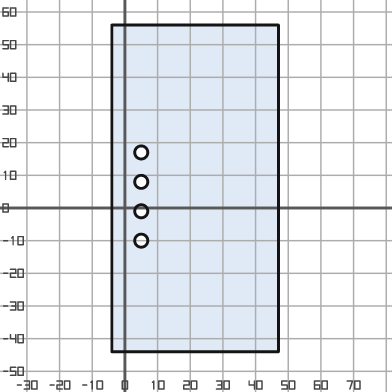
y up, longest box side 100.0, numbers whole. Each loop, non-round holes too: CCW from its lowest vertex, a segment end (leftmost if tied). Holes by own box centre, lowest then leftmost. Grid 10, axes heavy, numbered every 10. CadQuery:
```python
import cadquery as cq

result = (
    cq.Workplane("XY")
    .moveTo(-4.0, -44.0)
    .lineTo(47.0, -44.0)
    .lineTo(47.0, 56.0)
    .lineTo(-4.0, 56.0)
    .close()
    .moveTo(5.0, -10.0)
    .circle(2.0)
    .moveTo(5.0, -1.0)
    .circle(2.0)
    .moveTo(5.0, 8.0)
    .circle(2.0)
    .moveTo(5.0, 17.0)
    .circle(2.0)
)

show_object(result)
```